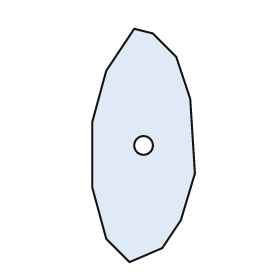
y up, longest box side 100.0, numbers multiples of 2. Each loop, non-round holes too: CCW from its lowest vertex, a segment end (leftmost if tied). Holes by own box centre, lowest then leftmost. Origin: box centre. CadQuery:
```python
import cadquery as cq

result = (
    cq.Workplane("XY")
    .moveTo(-6.0, -50.0)
    .lineTo(8.0, -44.0)
    .lineTo(16.0, -32.0)
    .lineTo(22.0, -12.0)
    .lineTo(20.0, 20.0)
    .lineTo(14.0, 38.0)
    .lineTo(4.0, 48.0)
    .lineTo(-4.0, 50.0)
    .lineTo(-16.0, 32.0)
    .lineTo(-22.0, 10.0)
    .lineTo(-22.0, -18.0)
    .lineTo(-16.0, -40.0)
    .close()
    .moveTo(0.0, 0.0)
    .circle(4.0)
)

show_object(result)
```